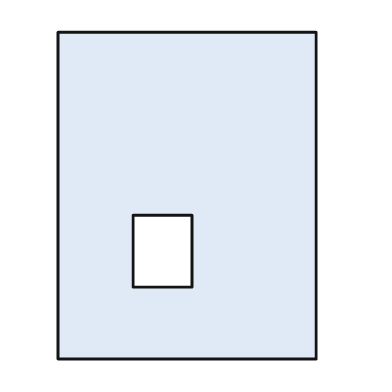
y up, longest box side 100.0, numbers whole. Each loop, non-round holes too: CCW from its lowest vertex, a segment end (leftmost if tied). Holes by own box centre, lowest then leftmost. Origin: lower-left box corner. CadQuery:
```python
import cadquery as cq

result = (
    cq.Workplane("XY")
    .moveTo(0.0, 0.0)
    .lineTo(79.0, 0.0)
    .lineTo(79.0, 100.0)
    .lineTo(0.0, 100.0)
    .close()
    .moveTo(23.0, 22.0)
    .lineTo(41.0, 22.0)
    .lineTo(41.0, 44.0)
    .lineTo(23.0, 44.0)
    .close()
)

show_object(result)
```